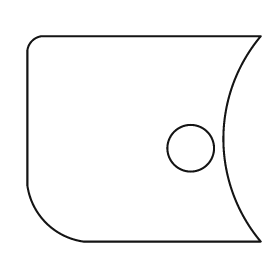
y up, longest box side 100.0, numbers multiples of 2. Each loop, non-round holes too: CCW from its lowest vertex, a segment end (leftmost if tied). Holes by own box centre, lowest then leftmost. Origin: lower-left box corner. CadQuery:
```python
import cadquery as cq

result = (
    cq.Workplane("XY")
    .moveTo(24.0, 0.0)
    .lineTo(100.0, 0.0)
    .threePointArc((84.0, 44.0), (100.0, 88.0))
    .lineTo(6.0, 88.0)
    .threePointArc((2.0, 86.0), (0.0, 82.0))
    .lineTo(0.0, 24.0)
    .threePointArc((8.0, 8.0), (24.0, 0.0))
    .close()
    .moveTo(70.0, 40.0)
    .circle(10.0)
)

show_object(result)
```